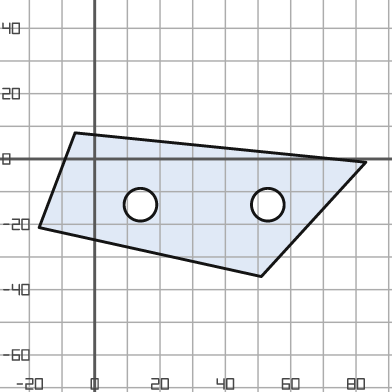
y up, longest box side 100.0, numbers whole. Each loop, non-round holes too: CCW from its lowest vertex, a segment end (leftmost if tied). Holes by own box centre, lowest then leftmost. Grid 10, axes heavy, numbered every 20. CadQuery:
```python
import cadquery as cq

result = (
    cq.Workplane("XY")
    .moveTo(51.0, -36.0)
    .lineTo(83.0, -1.0)
    .lineTo(-6.0, 8.0)
    .lineTo(-17.0, -21.0)
    .close()
    .moveTo(14.0, -14.0)
    .circle(5.0)
    .moveTo(53.0, -14.0)
    .circle(5.0)
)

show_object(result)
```